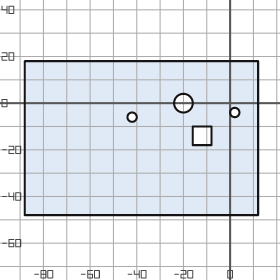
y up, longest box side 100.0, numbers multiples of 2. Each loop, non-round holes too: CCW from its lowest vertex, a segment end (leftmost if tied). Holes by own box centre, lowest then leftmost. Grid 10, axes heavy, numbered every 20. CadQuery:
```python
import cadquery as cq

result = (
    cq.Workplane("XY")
    .moveTo(-88.0, -48.0)
    .lineTo(12.0, -48.0)
    .lineTo(12.0, 18.0)
    .lineTo(-88.0, 18.0)
    .close()
    .moveTo(-16.0, -18.0)
    .lineTo(-8.0, -18.0)
    .lineTo(-8.0, -10.0)
    .lineTo(-16.0, -10.0)
    .close()
    .moveTo(-42.0, -6.0)
    .circle(2.0)
    .moveTo(2.0, -4.0)
    .circle(2.0)
    .moveTo(-20.0, 0.0)
    .circle(4.0)
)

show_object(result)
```